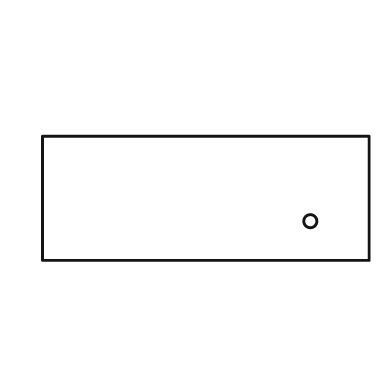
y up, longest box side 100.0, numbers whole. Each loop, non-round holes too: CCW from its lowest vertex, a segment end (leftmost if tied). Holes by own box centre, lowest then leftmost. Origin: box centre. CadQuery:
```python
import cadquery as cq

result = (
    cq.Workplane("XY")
    .moveTo(-50.0, -19.0)
    .lineTo(50.0, -19.0)
    .lineTo(50.0, 19.0)
    .lineTo(-50.0, 19.0)
    .close()
    .moveTo(32.0, -7.0)
    .circle(2.0)
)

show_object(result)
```